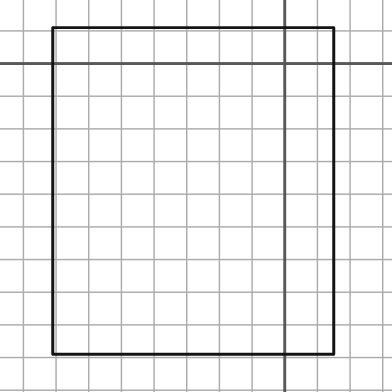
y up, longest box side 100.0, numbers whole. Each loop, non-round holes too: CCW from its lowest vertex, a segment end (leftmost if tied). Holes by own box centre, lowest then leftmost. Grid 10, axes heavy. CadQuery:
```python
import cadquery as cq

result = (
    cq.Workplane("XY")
    .moveTo(-71.0, -89.0)
    .lineTo(15.0, -89.0)
    .lineTo(15.0, 11.0)
    .lineTo(-71.0, 11.0)
    .close()
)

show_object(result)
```